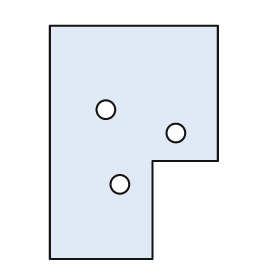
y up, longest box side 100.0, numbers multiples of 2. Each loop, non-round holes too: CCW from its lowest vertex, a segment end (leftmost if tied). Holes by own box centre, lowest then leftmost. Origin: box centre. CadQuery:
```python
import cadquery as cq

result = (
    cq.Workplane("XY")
    .moveTo(-36.0, -50.0)
    .lineTo(8.0, -50.0)
    .lineTo(8.0, -8.0)
    .lineTo(36.0, -8.0)
    .lineTo(36.0, 50.0)
    .lineTo(-36.0, 50.0)
    .close()
    .moveTo(-6.0, -18.0)
    .circle(4.0)
    .moveTo(18.0, 4.0)
    .circle(4.0)
    .moveTo(-12.0, 14.0)
    .circle(4.0)
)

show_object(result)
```